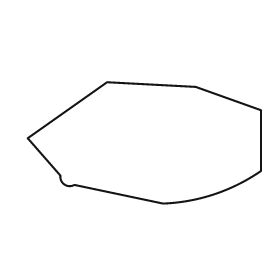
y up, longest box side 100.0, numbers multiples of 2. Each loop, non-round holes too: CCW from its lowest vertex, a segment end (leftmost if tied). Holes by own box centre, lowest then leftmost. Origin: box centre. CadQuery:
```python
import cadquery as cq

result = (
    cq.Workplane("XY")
    .moveTo(8.0, -26.0)
    .threePointArc((30.0, -22.0), (50.0, -12.0))
    .lineTo(50.0, 14.0)
    .lineTo(22.0, 24.0)
    .lineTo(-16.0, 26.0)
    .lineTo(-50.0, 2.0)
    .lineTo(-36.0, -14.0)
    .threePointArc((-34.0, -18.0), (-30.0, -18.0))
    .close()
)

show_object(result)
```